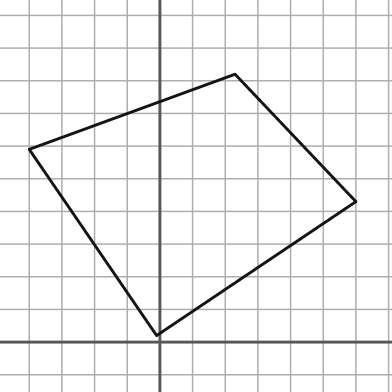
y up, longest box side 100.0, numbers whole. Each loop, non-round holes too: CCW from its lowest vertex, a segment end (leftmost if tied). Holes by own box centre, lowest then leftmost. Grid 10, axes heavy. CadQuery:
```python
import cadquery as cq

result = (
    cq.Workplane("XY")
    .moveTo(-1.0, 2.0)
    .lineTo(60.0, 43.0)
    .lineTo(23.0, 82.0)
    .lineTo(-40.0, 59.0)
    .close()
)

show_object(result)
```